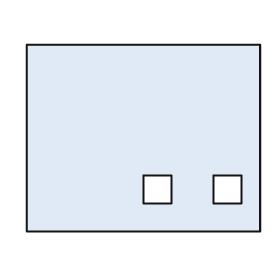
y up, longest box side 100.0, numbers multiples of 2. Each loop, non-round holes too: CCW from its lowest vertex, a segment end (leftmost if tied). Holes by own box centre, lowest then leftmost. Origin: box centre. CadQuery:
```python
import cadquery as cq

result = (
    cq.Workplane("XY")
    .moveTo(-50.0, -40.0)
    .lineTo(50.0, -40.0)
    .lineTo(50.0, 40.0)
    .lineTo(-50.0, 40.0)
    .close()
    .moveTo(0.0, -28.0)
    .lineTo(12.0, -28.0)
    .lineTo(12.0, -16.0)
    .lineTo(0.0, -16.0)
    .close()
    .moveTo(30.0, -28.0)
    .lineTo(42.0, -28.0)
    .lineTo(42.0, -16.0)
    .lineTo(30.0, -16.0)
    .close()
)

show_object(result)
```